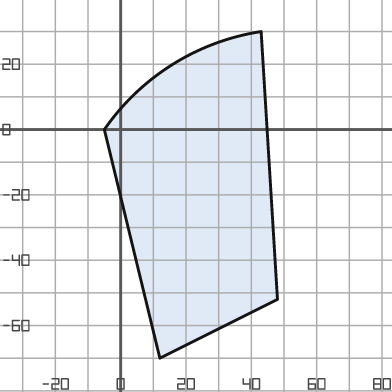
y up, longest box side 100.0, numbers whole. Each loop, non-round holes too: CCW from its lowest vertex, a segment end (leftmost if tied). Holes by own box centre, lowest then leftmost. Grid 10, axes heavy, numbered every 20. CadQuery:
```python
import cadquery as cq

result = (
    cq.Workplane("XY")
    .moveTo(12.0, -70.0)
    .lineTo(48.0, -52.0)
    .lineTo(43.0, 30.0)
    .threePointArc((16.0, 20.0), (-5.0, 0.0))
    .close()
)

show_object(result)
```